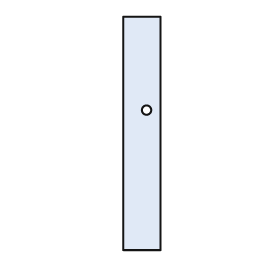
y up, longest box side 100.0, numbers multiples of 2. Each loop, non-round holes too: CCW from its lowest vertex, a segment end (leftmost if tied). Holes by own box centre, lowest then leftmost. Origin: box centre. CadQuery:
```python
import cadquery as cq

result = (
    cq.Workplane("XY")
    .moveTo(-8.0, -50.0)
    .lineTo(8.0, -50.0)
    .lineTo(8.0, 50.0)
    .lineTo(-8.0, 50.0)
    .close()
    .moveTo(2.0, 10.0)
    .circle(2.0)
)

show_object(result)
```